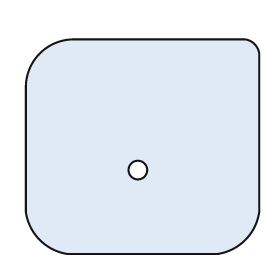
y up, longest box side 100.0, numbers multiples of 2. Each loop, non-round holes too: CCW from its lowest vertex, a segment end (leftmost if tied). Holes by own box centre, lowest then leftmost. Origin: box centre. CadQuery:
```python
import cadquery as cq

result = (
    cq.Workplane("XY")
    .moveTo(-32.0, -46.0)
    .lineTo(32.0, -46.0)
    .threePointArc((44.0, -40.0), (50.0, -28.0))
    .lineTo(50.0, 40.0)
    .threePointArc((48.0, 44.0), (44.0, 46.0))
    .lineTo(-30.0, 46.0)
    .threePointArc((-44.0, 40.0), (-50.0, 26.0))
    .lineTo(-50.0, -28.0)
    .threePointArc((-44.0, -40.0), (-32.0, -46.0))
    .close()
    .moveTo(-2.0, -10.0)
    .circle(4.0)
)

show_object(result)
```